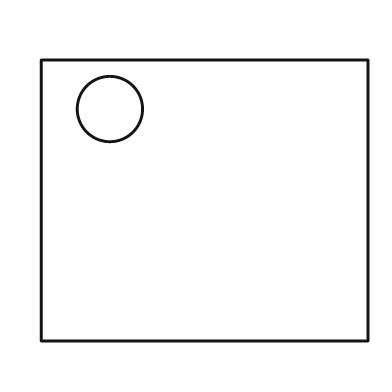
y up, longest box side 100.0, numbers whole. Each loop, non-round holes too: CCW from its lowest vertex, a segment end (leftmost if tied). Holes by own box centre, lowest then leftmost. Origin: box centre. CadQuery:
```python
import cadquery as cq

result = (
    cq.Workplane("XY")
    .moveTo(-50.0, -43.0)
    .lineTo(50.0, -43.0)
    .lineTo(50.0, 43.0)
    .lineTo(-50.0, 43.0)
    .close()
    .moveTo(-29.0, 28.0)
    .circle(10.0)
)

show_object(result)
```